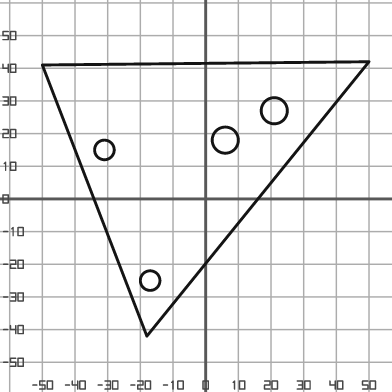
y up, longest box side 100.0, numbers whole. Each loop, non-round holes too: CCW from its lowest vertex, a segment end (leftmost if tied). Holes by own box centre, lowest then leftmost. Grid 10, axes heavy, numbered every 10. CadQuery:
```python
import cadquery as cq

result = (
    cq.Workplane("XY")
    .moveTo(-18.0, -42.0)
    .lineTo(50.0, 42.0)
    .lineTo(-50.0, 41.0)
    .close()
    .moveTo(-17.0, -25.0)
    .circle(3.0)
    .moveTo(-31.0, 15.0)
    .circle(3.0)
    .moveTo(6.0, 18.0)
    .circle(4.0)
    .moveTo(21.0, 27.0)
    .circle(4.0)
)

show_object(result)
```